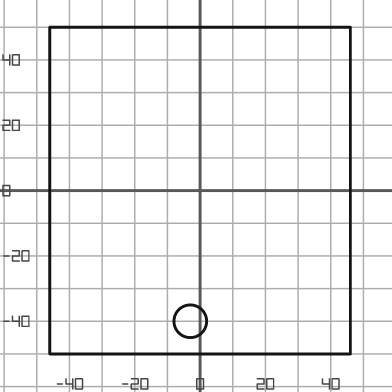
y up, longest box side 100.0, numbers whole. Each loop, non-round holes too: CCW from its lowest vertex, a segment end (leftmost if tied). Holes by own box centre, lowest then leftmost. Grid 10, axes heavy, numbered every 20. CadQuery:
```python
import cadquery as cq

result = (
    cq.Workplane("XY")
    .moveTo(-46.0, -50.0)
    .lineTo(46.0, -50.0)
    .lineTo(46.0, 50.0)
    .lineTo(-46.0, 50.0)
    .close()
    .moveTo(-3.0, -40.0)
    .circle(5.0)
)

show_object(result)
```